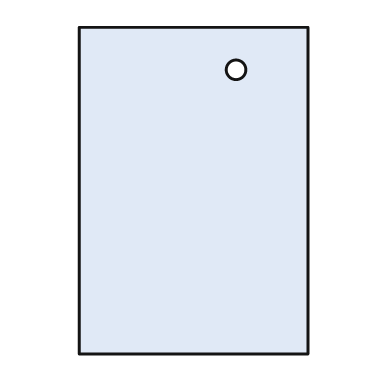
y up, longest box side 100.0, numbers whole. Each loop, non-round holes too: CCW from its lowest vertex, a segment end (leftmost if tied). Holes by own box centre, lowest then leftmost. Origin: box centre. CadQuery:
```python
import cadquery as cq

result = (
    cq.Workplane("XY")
    .moveTo(-35.0, -50.0)
    .lineTo(35.0, -50.0)
    .lineTo(35.0, 50.0)
    .lineTo(-35.0, 50.0)
    .close()
    .moveTo(13.0, 37.0)
    .circle(3.0)
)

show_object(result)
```